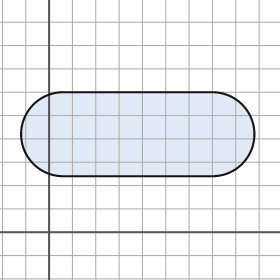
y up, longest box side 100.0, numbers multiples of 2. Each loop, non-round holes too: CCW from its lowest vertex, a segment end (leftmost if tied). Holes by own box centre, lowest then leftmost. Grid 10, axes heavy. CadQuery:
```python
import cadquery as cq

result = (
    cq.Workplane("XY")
    .moveTo(6.0, 24.0)
    .lineTo(70.0, 24.0)
    .threePointArc((88.0, 42.0), (70.0, 60.0))
    .lineTo(6.0, 60.0)
    .threePointArc((-12.0, 42.0), (6.0, 24.0))
    .close()
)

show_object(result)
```